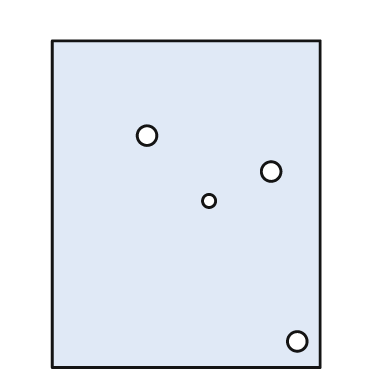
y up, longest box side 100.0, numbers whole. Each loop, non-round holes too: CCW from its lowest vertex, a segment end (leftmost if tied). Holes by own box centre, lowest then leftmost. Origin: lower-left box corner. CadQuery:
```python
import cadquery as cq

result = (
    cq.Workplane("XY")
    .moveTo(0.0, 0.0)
    .lineTo(82.0, 0.0)
    .lineTo(82.0, 100.0)
    .lineTo(0.0, 100.0)
    .close()
    .moveTo(75.0, 8.0)
    .circle(3.0)
    .moveTo(48.0, 51.0)
    .circle(2.0)
    .moveTo(67.0, 60.0)
    .circle(3.0)
    .moveTo(29.0, 71.0)
    .circle(3.0)
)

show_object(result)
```